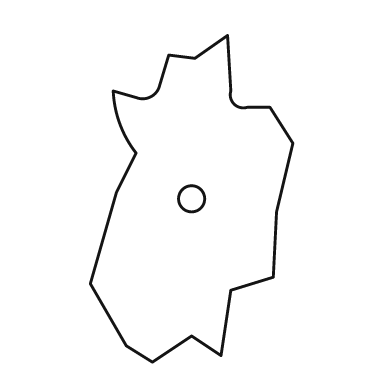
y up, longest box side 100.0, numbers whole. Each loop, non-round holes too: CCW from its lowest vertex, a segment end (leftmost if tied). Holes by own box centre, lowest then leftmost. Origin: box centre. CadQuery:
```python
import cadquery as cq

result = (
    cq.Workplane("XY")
    .moveTo(-12.0, -50.0)
    .lineTo(0.0, -42.0)
    .lineTo(9.0, -48.0)
    .lineTo(12.0, -28.0)
    .lineTo(25.0, -24.0)
    .lineTo(26.0, -4.0)
    .lineTo(31.0, 17.0)
    .lineTo(24.0, 28.0)
    .lineTo(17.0, 28.0)
    .threePointArc((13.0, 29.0), (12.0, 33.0))
    .lineTo(11.0, 50.0)
    .lineTo(1.0, 43.0)
    .lineTo(-7.0, 44.0)
    .lineTo(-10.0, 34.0)
    .threePointArc((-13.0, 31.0), (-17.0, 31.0))
    .lineTo(-24.0, 33.0)
    .threePointArc((-22.0, 23.0), (-17.0, 14.0))
    .lineTo(-23.0, 2.0)
    .lineTo(-31.0, -26.0)
    .lineTo(-20.0, -45.0)
    .close()
    .moveTo(0.0, 0.0)
    .circle(4.0)
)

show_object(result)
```